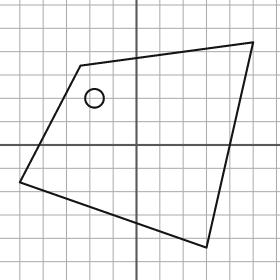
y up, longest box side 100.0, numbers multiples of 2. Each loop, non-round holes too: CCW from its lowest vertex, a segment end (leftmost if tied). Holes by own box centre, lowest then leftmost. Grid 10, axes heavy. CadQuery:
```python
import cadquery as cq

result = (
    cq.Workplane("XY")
    .moveTo(30.0, -44.0)
    .lineTo(50.0, 44.0)
    .lineTo(-24.0, 34.0)
    .lineTo(-50.0, -16.0)
    .close()
    .moveTo(-18.0, 20.0)
    .circle(4.0)
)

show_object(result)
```